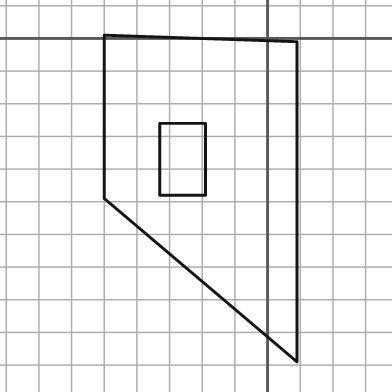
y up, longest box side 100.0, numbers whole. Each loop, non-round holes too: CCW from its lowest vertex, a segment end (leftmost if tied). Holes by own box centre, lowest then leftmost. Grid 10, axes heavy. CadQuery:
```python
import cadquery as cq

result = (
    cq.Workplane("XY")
    .moveTo(9.0, -99.0)
    .lineTo(9.0, -1.0)
    .lineTo(-50.0, 1.0)
    .lineTo(-50.0, -49.0)
    .close()
    .moveTo(-33.0, -48.0)
    .lineTo(-19.0, -48.0)
    .lineTo(-19.0, -26.0)
    .lineTo(-33.0, -26.0)
    .close()
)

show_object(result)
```